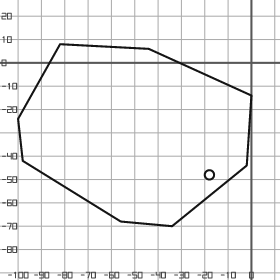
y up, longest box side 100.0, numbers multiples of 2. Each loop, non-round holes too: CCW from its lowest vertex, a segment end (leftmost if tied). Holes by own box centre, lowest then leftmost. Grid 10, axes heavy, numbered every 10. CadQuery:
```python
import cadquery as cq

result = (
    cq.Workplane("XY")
    .moveTo(-34.0, -70.0)
    .lineTo(-2.0, -44.0)
    .lineTo(0.0, -14.0)
    .lineTo(-44.0, 6.0)
    .lineTo(-82.0, 8.0)
    .lineTo(-100.0, -24.0)
    .lineTo(-98.0, -42.0)
    .lineTo(-56.0, -68.0)
    .close()
    .moveTo(-18.0, -48.0)
    .circle(2.0)
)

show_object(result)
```